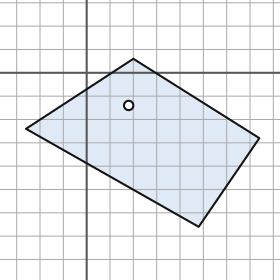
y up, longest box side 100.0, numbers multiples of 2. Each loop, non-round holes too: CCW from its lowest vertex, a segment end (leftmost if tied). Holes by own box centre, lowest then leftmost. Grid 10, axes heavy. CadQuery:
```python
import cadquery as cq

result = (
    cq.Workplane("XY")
    .moveTo(48.0, -66.0)
    .lineTo(74.0, -28.0)
    .lineTo(20.0, 6.0)
    .lineTo(-26.0, -24.0)
    .close()
    .moveTo(18.0, -14.0)
    .circle(2.0)
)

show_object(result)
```